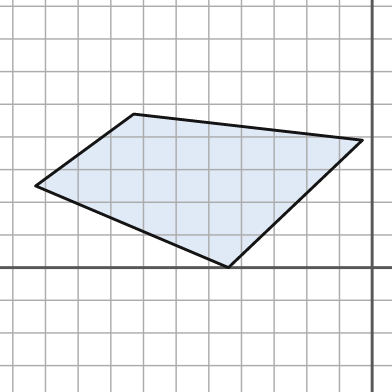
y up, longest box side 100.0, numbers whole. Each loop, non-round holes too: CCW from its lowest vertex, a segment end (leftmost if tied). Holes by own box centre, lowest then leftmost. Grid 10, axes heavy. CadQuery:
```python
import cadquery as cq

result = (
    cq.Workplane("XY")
    .moveTo(-44.0, 0.0)
    .lineTo(-3.0, 39.0)
    .lineTo(-73.0, 47.0)
    .lineTo(-103.0, 25.0)
    .close()
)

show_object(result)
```